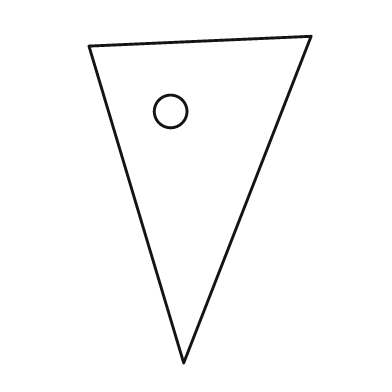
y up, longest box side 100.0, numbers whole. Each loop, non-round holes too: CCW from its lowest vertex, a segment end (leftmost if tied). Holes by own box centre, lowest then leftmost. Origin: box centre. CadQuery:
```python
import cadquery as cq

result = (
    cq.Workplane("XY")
    .moveTo(-5.0, -50.0)
    .lineTo(34.0, 50.0)
    .lineTo(-34.0, 47.0)
    .close()
    .moveTo(-9.0, 27.0)
    .circle(5.0)
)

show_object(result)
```